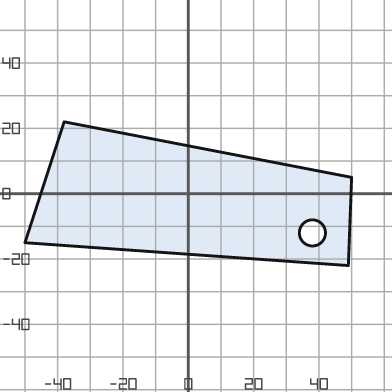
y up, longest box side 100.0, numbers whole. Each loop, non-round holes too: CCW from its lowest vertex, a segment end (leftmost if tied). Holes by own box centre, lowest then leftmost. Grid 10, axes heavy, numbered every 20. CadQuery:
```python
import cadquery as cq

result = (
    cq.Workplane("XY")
    .moveTo(49.0, -22.0)
    .lineTo(50.0, 5.0)
    .lineTo(-38.0, 22.0)
    .lineTo(-50.0, -15.0)
    .close()
    .moveTo(38.0, -12.0)
    .circle(4.0)
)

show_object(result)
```